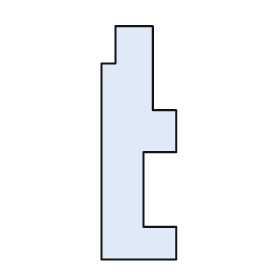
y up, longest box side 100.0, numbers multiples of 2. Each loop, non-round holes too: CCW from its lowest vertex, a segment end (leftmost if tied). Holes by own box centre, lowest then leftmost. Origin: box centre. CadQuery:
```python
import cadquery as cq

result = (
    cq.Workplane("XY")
    .moveTo(-16.0, -50.0)
    .lineTo(16.0, -50.0)
    .lineTo(16.0, -36.0)
    .lineTo(2.0, -36.0)
    .lineTo(2.0, -4.0)
    .lineTo(16.0, -4.0)
    .lineTo(16.0, 14.0)
    .lineTo(6.0, 14.0)
    .lineTo(6.0, 50.0)
    .lineTo(-10.0, 50.0)
    .lineTo(-10.0, 34.0)
    .lineTo(-16.0, 34.0)
    .close()
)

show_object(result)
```